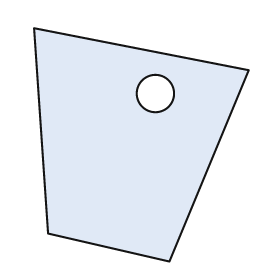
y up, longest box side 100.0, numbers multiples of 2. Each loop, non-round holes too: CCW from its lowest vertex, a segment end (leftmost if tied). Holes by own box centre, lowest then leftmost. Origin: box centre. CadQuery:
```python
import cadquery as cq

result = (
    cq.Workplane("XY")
    .moveTo(12.0, -50.0)
    .lineTo(46.0, 32.0)
    .lineTo(-46.0, 50.0)
    .lineTo(-40.0, -38.0)
    .close()
    .moveTo(6.0, 22.0)
    .circle(8.0)
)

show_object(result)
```